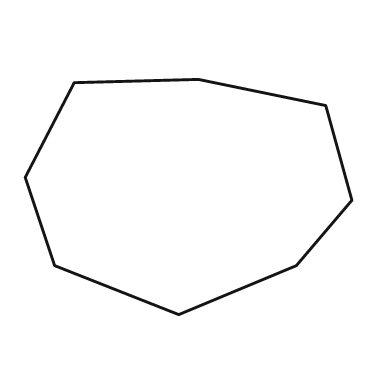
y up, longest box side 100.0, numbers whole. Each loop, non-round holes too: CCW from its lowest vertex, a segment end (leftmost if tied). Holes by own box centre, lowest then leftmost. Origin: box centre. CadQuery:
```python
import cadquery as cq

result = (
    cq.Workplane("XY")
    .moveTo(-3.0, -36.0)
    .lineTo(33.0, -21.0)
    .lineTo(50.0, -1.0)
    .lineTo(42.0, 28.0)
    .lineTo(3.0, 36.0)
    .lineTo(-35.0, 35.0)
    .lineTo(-50.0, 6.0)
    .lineTo(-41.0, -21.0)
    .close()
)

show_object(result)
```